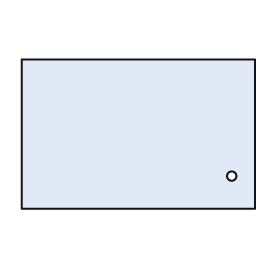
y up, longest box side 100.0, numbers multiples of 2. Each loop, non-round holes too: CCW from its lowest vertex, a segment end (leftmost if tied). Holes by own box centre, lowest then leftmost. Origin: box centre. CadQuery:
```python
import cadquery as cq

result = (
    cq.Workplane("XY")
    .moveTo(-50.0, -32.0)
    .lineTo(50.0, -32.0)
    .lineTo(50.0, 32.0)
    .lineTo(-50.0, 32.0)
    .close()
    .moveTo(40.0, -18.0)
    .circle(2.0)
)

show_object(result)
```